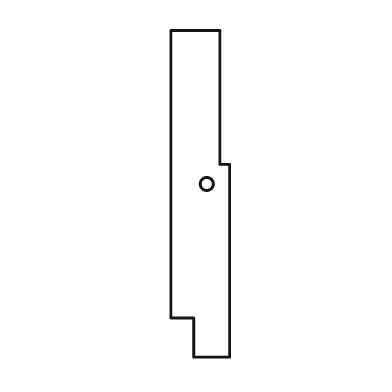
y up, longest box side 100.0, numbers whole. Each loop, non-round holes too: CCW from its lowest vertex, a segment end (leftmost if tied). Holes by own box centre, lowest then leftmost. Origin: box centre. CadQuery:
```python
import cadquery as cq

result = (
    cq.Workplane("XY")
    .moveTo(-2.0, -50.0)
    .lineTo(9.0, -50.0)
    .lineTo(9.0, 9.0)
    .lineTo(6.0, 9.0)
    .lineTo(6.0, 50.0)
    .lineTo(-9.0, 50.0)
    .lineTo(-9.0, -38.0)
    .lineTo(-2.0, -38.0)
    .close()
    .moveTo(2.0, 3.0)
    .circle(2.0)
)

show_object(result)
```